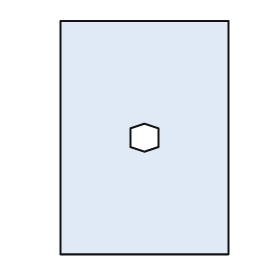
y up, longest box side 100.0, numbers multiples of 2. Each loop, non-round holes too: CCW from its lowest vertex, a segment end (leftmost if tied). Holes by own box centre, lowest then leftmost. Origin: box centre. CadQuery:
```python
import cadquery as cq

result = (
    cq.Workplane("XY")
    .moveTo(-36.0, -50.0)
    .lineTo(36.0, -50.0)
    .lineTo(36.0, 50.0)
    .lineTo(-36.0, 50.0)
    .close()
    .moveTo(0.0, -6.0)
    .lineTo(6.0, -4.0)
    .lineTo(6.0, 4.0)
    .lineTo(0.0, 6.0)
    .lineTo(-6.0, 4.0)
    .lineTo(-6.0, -4.0)
    .close()
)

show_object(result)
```